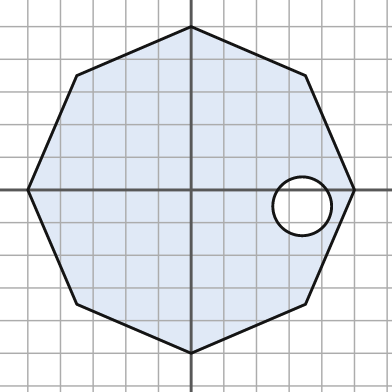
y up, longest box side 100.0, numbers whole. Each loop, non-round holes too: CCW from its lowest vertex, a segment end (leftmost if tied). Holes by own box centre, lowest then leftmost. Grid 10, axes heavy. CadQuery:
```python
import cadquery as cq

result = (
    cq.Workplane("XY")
    .moveTo(0.0, -50.0)
    .lineTo(35.0, -35.0)
    .lineTo(50.0, 0.0)
    .lineTo(35.0, 35.0)
    .lineTo(0.0, 50.0)
    .lineTo(-35.0, 35.0)
    .lineTo(-50.0, 0.0)
    .lineTo(-35.0, -35.0)
    .close()
    .moveTo(34.0, -5.0)
    .circle(9.0)
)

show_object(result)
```